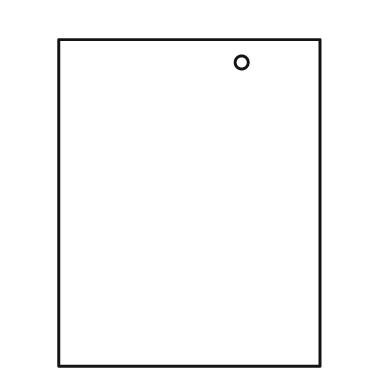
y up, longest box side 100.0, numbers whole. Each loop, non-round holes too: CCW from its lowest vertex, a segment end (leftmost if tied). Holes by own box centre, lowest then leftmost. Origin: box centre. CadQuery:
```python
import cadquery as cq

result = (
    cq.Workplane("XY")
    .moveTo(-40.0, -50.0)
    .lineTo(40.0, -50.0)
    .lineTo(40.0, 50.0)
    .lineTo(-40.0, 50.0)
    .close()
    .moveTo(16.0, 43.0)
    .circle(2.0)
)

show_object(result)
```